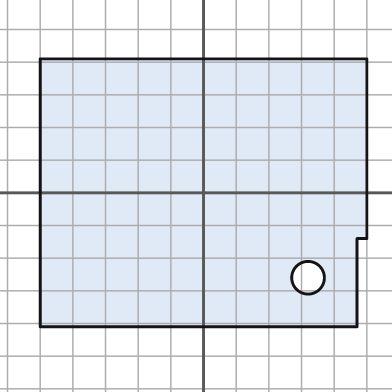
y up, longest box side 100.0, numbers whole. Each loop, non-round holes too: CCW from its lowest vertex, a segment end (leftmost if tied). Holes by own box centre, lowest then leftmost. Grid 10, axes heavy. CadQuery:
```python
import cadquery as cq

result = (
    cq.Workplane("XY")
    .moveTo(-50.0, -41.0)
    .lineTo(47.0, -41.0)
    .lineTo(47.0, -14.0)
    .lineTo(50.0, -14.0)
    .lineTo(50.0, 41.0)
    .lineTo(-50.0, 41.0)
    .close()
    .moveTo(32.0, -26.0)
    .circle(5.0)
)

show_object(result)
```